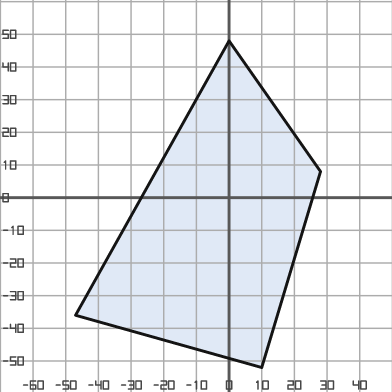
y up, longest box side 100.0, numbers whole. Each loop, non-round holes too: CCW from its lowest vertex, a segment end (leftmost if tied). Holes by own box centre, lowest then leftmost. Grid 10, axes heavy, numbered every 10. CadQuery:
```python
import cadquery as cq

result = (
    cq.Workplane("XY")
    .moveTo(10.0, -52.0)
    .lineTo(28.0, 8.0)
    .lineTo(0.0, 48.0)
    .lineTo(-47.0, -36.0)
    .close()
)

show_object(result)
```